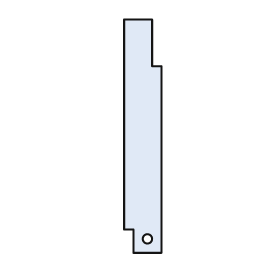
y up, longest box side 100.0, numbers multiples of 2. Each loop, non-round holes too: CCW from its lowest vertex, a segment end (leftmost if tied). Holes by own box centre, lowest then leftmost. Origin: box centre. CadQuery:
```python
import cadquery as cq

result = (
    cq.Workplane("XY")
    .moveTo(-4.0, -50.0)
    .lineTo(8.0, -50.0)
    .lineTo(8.0, 30.0)
    .lineTo(4.0, 30.0)
    .lineTo(4.0, 50.0)
    .lineTo(-8.0, 50.0)
    .lineTo(-8.0, -40.0)
    .lineTo(-4.0, -40.0)
    .close()
    .moveTo(2.0, -44.0)
    .circle(2.0)
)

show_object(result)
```